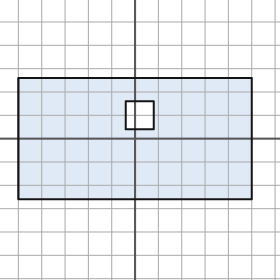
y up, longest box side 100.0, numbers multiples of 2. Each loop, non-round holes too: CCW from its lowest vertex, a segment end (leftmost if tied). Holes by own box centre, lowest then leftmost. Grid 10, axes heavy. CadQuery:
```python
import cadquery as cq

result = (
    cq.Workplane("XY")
    .moveTo(-50.0, -26.0)
    .lineTo(50.0, -26.0)
    .lineTo(50.0, 26.0)
    .lineTo(-50.0, 26.0)
    .close()
    .moveTo(-4.0, 4.0)
    .lineTo(8.0, 4.0)
    .lineTo(8.0, 16.0)
    .lineTo(-4.0, 16.0)
    .close()
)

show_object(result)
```